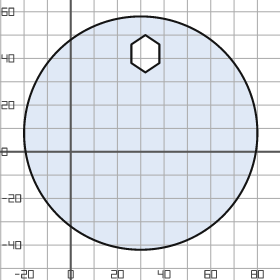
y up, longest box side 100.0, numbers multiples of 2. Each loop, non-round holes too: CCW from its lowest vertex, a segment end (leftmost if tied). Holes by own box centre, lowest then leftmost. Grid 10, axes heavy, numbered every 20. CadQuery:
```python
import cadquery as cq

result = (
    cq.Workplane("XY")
    .moveTo(30.0, 8.0)
    .circle(50.0)
    .moveTo(32.0, 34.0)
    .lineTo(38.0, 38.0)
    .lineTo(38.0, 46.0)
    .lineTo(32.0, 50.0)
    .lineTo(26.0, 46.0)
    .lineTo(26.0, 38.0)
    .close()
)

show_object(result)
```